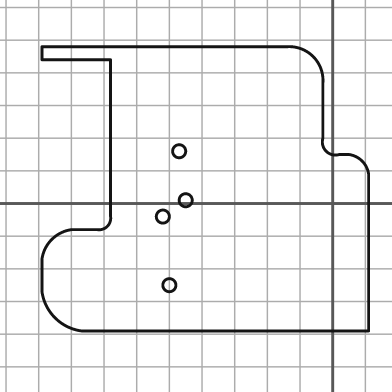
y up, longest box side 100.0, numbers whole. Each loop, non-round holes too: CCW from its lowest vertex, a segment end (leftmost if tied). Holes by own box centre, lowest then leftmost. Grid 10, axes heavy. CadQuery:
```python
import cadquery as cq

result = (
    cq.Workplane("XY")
    .moveTo(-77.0, -39.0)
    .lineTo(11.0, -39.0)
    .lineTo(11.0, 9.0)
    .threePointArc((9.0, 13.0), (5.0, 15.0))
    .lineTo(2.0, 15.0)
    .threePointArc((-2.0, 16.0), (-3.0, 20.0))
    .lineTo(-3.0, 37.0)
    .threePointArc((-6.0, 45.0), (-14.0, 48.0))
    .lineTo(-89.0, 48.0)
    .lineTo(-89.0, 44.0)
    .lineTo(-68.0, 44.0)
    .lineTo(-68.0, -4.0)
    .threePointArc((-69.0, -7.0), (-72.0, -8.0))
    .lineTo(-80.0, -8.0)
    .threePointArc((-86.0, -11.0), (-89.0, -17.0))
    .lineTo(-89.0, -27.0)
    .threePointArc((-85.0, -35.0), (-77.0, -39.0))
    .close()
    .moveTo(-50.0, -25.0)
    .circle(2.0)
    .moveTo(-52.0, -4.0)
    .circle(2.0)
    .moveTo(-45.0, 1.0)
    .circle(2.0)
    .moveTo(-47.0, 16.0)
    .circle(2.0)
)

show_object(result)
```